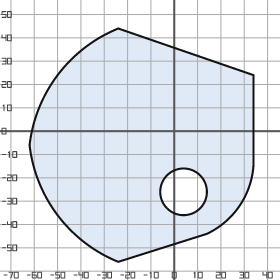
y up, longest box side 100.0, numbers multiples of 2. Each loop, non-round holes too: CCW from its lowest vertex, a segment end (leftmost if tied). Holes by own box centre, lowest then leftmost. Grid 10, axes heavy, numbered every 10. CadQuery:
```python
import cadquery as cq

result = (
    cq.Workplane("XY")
    .moveTo(-24.0, -56.0)
    .lineTo(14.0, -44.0)
    .threePointArc((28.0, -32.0), (34.0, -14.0))
    .lineTo(34.0, 24.0)
    .lineTo(-24.0, 44.0)
    .threePointArc((-50.0, 24.0), (-62.0, -6.0))
    .threePointArc((-50.0, -36.0), (-24.0, -56.0))
    .close()
    .moveTo(4.0, -26.0)
    .circle(10.0)
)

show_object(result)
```